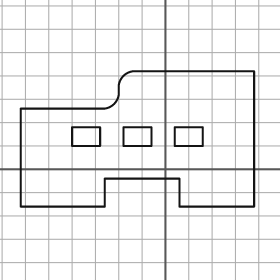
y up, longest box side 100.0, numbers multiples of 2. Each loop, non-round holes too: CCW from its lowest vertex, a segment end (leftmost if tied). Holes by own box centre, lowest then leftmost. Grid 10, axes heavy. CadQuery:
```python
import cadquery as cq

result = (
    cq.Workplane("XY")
    .moveTo(-62.0, -16.0)
    .lineTo(-26.0, -16.0)
    .lineTo(-26.0, -4.0)
    .lineTo(6.0, -4.0)
    .lineTo(6.0, -16.0)
    .lineTo(38.0, -16.0)
    .lineTo(38.0, 42.0)
    .lineTo(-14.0, 42.0)
    .threePointArc((-18.0, 40.0), (-20.0, 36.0))
    .lineTo(-20.0, 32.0)
    .threePointArc((-22.0, 28.0), (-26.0, 26.0))
    .lineTo(-62.0, 26.0)
    .close()
    .moveTo(-40.0, 10.0)
    .lineTo(-28.0, 10.0)
    .lineTo(-28.0, 18.0)
    .lineTo(-40.0, 18.0)
    .close()
    .moveTo(-18.0, 10.0)
    .lineTo(-6.0, 10.0)
    .lineTo(-6.0, 18.0)
    .lineTo(-18.0, 18.0)
    .close()
    .moveTo(4.0, 10.0)
    .lineTo(16.0, 10.0)
    .lineTo(16.0, 18.0)
    .lineTo(4.0, 18.0)
    .close()
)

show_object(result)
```